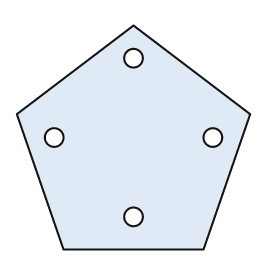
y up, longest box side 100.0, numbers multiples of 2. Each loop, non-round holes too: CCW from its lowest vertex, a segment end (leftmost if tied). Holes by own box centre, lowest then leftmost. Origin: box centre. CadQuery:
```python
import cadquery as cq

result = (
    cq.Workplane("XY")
    .moveTo(-30.0, -48.0)
    .lineTo(30.0, -48.0)
    .lineTo(50.0, 10.0)
    .lineTo(0.0, 48.0)
    .lineTo(-50.0, 10.0)
    .close()
    .moveTo(0.0, -34.0)
    .circle(4.0)
    .moveTo(-34.0, 0.0)
    .circle(4.0)
    .moveTo(34.0, 0.0)
    .circle(4.0)
    .moveTo(0.0, 34.0)
    .circle(4.0)
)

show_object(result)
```